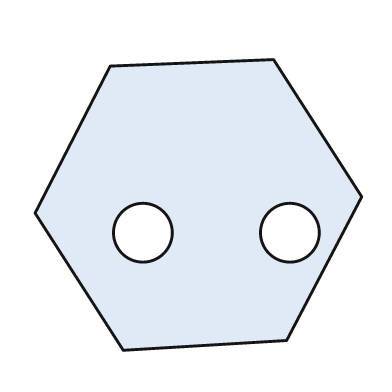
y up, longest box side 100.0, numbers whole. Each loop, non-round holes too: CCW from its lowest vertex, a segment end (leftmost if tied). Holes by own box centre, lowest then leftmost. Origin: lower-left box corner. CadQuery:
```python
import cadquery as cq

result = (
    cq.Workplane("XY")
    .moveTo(27.0, 0.0)
    .lineTo(77.0, 3.0)
    .lineTo(100.0, 47.0)
    .lineTo(73.0, 89.0)
    .lineTo(23.0, 87.0)
    .lineTo(0.0, 42.0)
    .close()
    .moveTo(33.0, 36.0)
    .circle(9.0)
    .moveTo(78.0, 36.0)
    .circle(9.0)
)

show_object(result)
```